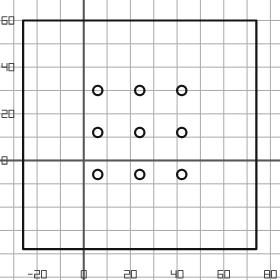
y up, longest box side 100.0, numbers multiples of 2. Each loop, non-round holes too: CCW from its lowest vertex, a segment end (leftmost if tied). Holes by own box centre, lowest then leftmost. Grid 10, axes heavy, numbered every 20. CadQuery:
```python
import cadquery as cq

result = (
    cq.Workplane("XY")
    .moveTo(-26.0, -38.0)
    .lineTo(74.0, -38.0)
    .lineTo(74.0, 60.0)
    .lineTo(-26.0, 60.0)
    .close()
    .moveTo(6.0, -6.0)
    .circle(2.0)
    .moveTo(24.0, -6.0)
    .circle(2.0)
    .moveTo(42.0, -6.0)
    .circle(2.0)
    .moveTo(6.0, 12.0)
    .circle(2.0)
    .moveTo(24.0, 12.0)
    .circle(2.0)
    .moveTo(42.0, 12.0)
    .circle(2.0)
    .moveTo(6.0, 30.0)
    .circle(2.0)
    .moveTo(24.0, 30.0)
    .circle(2.0)
    .moveTo(42.0, 30.0)
    .circle(2.0)
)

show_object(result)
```